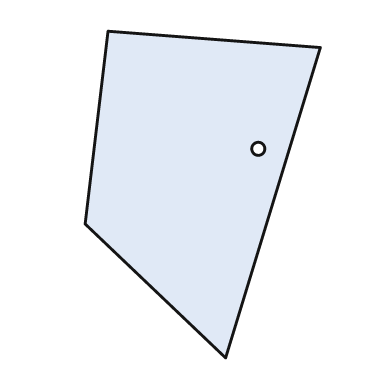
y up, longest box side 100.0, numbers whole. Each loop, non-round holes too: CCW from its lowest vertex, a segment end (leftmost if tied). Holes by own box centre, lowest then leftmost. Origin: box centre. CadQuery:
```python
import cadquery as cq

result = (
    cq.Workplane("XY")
    .moveTo(7.0, -50.0)
    .lineTo(36.0, 45.0)
    .lineTo(-29.0, 50.0)
    .lineTo(-36.0, -9.0)
    .close()
    .moveTo(17.0, 14.0)
    .circle(2.0)
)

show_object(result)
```